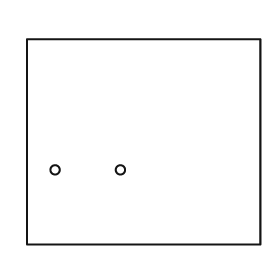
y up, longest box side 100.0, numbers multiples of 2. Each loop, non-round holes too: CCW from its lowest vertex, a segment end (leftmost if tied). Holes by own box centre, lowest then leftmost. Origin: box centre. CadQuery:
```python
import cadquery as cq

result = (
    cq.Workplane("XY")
    .moveTo(-50.0, -44.0)
    .lineTo(50.0, -44.0)
    .lineTo(50.0, 44.0)
    .lineTo(-50.0, 44.0)
    .close()
    .moveTo(-38.0, -12.0)
    .circle(2.0)
    .moveTo(-10.0, -12.0)
    .circle(2.0)
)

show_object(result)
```